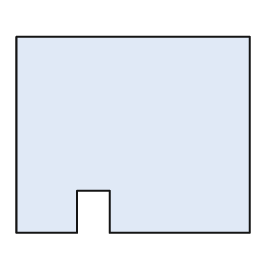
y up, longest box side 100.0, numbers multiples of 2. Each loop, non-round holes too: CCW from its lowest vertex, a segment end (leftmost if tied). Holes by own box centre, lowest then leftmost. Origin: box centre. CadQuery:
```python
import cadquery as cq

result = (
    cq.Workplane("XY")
    .moveTo(-50.0, -42.0)
    .lineTo(-24.0, -42.0)
    .lineTo(-24.0, -24.0)
    .lineTo(-10.0, -24.0)
    .lineTo(-10.0, -42.0)
    .lineTo(50.0, -42.0)
    .lineTo(50.0, 42.0)
    .lineTo(-50.0, 42.0)
    .close()
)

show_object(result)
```